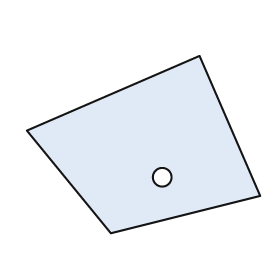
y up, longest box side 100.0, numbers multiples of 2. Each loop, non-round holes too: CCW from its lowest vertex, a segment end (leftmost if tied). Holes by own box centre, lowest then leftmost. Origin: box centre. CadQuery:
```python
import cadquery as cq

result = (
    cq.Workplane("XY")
    .moveTo(-14.0, -38.0)
    .lineTo(50.0, -22.0)
    .lineTo(24.0, 38.0)
    .lineTo(-50.0, 6.0)
    .close()
    .moveTo(8.0, -14.0)
    .circle(4.0)
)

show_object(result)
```